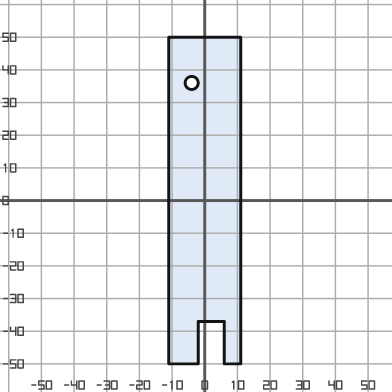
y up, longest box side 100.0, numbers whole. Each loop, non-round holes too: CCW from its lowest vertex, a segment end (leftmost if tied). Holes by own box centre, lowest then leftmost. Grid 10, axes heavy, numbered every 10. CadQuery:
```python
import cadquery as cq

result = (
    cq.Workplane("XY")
    .moveTo(-11.0, -50.0)
    .lineTo(-2.0, -50.0)
    .lineTo(-2.0, -37.0)
    .lineTo(6.0, -37.0)
    .lineTo(6.0, -50.0)
    .lineTo(11.0, -50.0)
    .lineTo(11.0, 50.0)
    .lineTo(-11.0, 50.0)
    .close()
    .moveTo(-4.0, 36.0)
    .circle(2.0)
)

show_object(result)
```